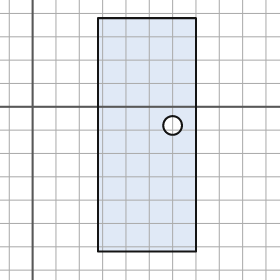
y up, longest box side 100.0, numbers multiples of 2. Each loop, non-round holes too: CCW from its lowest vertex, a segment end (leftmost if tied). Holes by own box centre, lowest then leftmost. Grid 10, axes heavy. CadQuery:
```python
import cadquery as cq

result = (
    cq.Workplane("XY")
    .moveTo(28.0, -62.0)
    .lineTo(70.0, -62.0)
    .lineTo(70.0, 38.0)
    .lineTo(28.0, 38.0)
    .close()
    .moveTo(60.0, -8.0)
    .circle(4.0)
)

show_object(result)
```